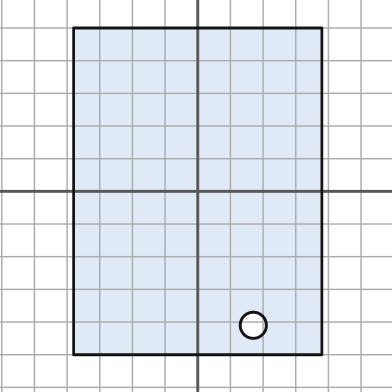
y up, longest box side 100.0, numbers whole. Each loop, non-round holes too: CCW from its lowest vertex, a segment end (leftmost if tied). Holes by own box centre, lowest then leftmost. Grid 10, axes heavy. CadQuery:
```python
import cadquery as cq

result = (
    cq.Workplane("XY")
    .moveTo(-38.0, -50.0)
    .lineTo(38.0, -50.0)
    .lineTo(38.0, 50.0)
    .lineTo(-38.0, 50.0)
    .close()
    .moveTo(17.0, -41.0)
    .circle(4.0)
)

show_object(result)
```